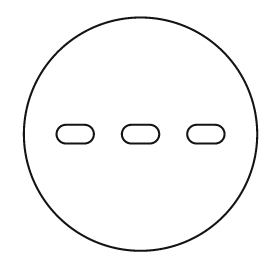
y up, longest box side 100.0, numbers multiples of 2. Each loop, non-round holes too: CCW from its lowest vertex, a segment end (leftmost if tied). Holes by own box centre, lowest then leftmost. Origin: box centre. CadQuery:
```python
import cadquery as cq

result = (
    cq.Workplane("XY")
    .moveTo(0.0, 0.0)
    .circle(50.0)
    .moveTo(-32.0, -4.0)
    .lineTo(-24.0, -4.0)
    .threePointArc((-20.0, 0.0), (-24.0, 4.0))
    .lineTo(-32.0, 4.0)
    .threePointArc((-36.0, 0.0), (-32.0, -4.0))
    .close()
    .moveTo(-4.0, -4.0)
    .lineTo(4.0, -4.0)
    .threePointArc((8.0, 0.0), (4.0, 4.0))
    .lineTo(-4.0, 4.0)
    .threePointArc((-8.0, 0.0), (-4.0, -4.0))
    .close()
    .moveTo(24.0, -4.0)
    .lineTo(32.0, -4.0)
    .threePointArc((36.0, 0.0), (32.0, 4.0))
    .lineTo(24.0, 4.0)
    .threePointArc((20.0, 0.0), (24.0, -4.0))
    .close()
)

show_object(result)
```